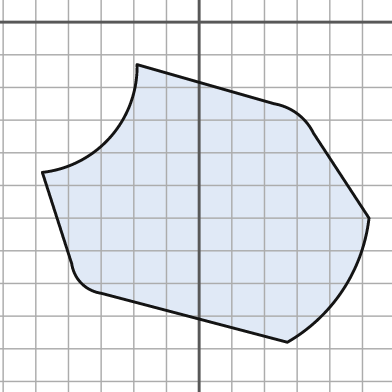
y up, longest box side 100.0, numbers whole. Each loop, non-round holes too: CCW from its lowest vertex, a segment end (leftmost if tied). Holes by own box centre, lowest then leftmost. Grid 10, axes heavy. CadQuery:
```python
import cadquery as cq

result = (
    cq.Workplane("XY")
    .moveTo(27.0, -98.0)
    .threePointArc((44.0, -82.0), (52.0, -60.0))
    .lineTo(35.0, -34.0)
    .threePointArc((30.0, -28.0), (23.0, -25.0))
    .lineTo(-19.0, -13.0)
    .threePointArc((-27.0, -35.0), (-48.0, -46.0))
    .lineTo(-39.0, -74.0)
    .threePointArc((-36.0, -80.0), (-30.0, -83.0))
    .close()
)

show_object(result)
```